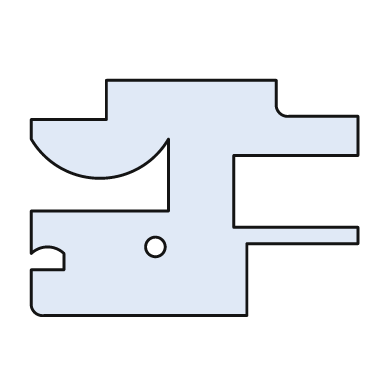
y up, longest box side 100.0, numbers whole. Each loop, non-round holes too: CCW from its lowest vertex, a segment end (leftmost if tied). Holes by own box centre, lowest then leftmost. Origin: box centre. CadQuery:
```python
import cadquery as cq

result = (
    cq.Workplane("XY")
    .moveTo(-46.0, -36.0)
    .lineTo(16.0, -36.0)
    .lineTo(16.0, -14.0)
    .lineTo(50.0, -14.0)
    .lineTo(50.0, -9.0)
    .lineTo(12.0, -9.0)
    .lineTo(12.0, 13.0)
    .lineTo(50.0, 13.0)
    .lineTo(50.0, 25.0)
    .lineTo(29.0, 25.0)
    .threePointArc((26.0, 26.0), (25.0, 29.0))
    .lineTo(25.0, 36.0)
    .lineTo(-27.0, 36.0)
    .lineTo(-27.0, 24.0)
    .lineTo(-50.0, 24.0)
    .lineTo(-50.0, 18.0)
    .threePointArc((-29.0, 6.0), (-8.0, 18.0))
    .lineTo(-8.0, -4.0)
    .lineTo(-50.0, -4.0)
    .lineTo(-50.0, -17.0)
    .threePointArc((-45.0, -15.0), (-40.0, -17.0))
    .lineTo(-40.0, -22.0)
    .lineTo(-50.0, -22.0)
    .lineTo(-50.0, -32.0)
    .threePointArc((-49.0, -35.0), (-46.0, -36.0))
    .close()
    .moveTo(-12.0, -15.0)
    .circle(3.0)
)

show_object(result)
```